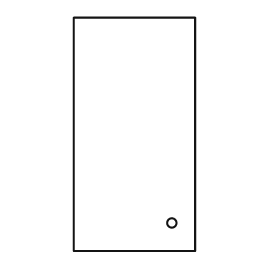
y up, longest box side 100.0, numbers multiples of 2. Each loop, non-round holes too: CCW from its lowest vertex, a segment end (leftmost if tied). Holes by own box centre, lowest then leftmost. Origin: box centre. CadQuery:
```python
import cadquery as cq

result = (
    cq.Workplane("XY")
    .moveTo(-26.0, -50.0)
    .lineTo(26.0, -50.0)
    .lineTo(26.0, 50.0)
    .lineTo(-26.0, 50.0)
    .close()
    .moveTo(16.0, -38.0)
    .circle(2.0)
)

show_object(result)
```